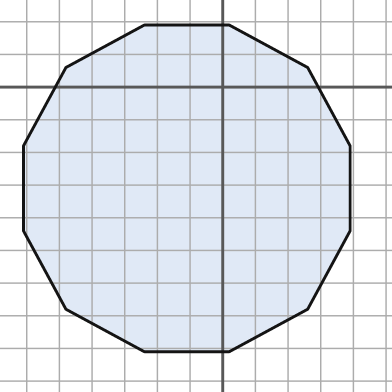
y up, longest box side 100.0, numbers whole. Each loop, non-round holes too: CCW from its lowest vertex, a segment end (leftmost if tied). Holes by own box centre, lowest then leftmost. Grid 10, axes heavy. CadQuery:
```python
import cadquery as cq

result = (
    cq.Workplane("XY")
    .moveTo(-24.0, -81.0)
    .lineTo(2.0, -81.0)
    .lineTo(26.0, -68.0)
    .lineTo(39.0, -44.0)
    .lineTo(39.0, -18.0)
    .lineTo(26.0, 6.0)
    .lineTo(2.0, 19.0)
    .lineTo(-24.0, 19.0)
    .lineTo(-48.0, 6.0)
    .lineTo(-61.0, -18.0)
    .lineTo(-61.0, -44.0)
    .lineTo(-48.0, -68.0)
    .close()
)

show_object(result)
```